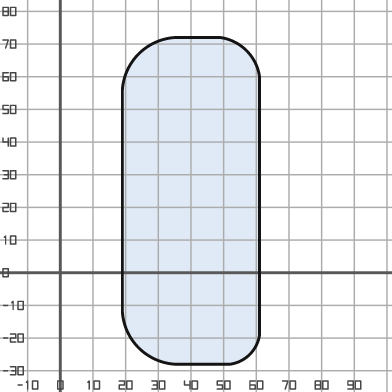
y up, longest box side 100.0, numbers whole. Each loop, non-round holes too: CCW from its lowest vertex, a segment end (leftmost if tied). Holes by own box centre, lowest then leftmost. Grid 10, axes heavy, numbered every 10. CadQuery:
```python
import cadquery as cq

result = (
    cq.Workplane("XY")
    .moveTo(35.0, -28.0)
    .lineTo(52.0, -28.0)
    .threePointArc((58.0, -25.0), (61.0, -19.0))
    .lineTo(61.0, 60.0)
    .threePointArc((57.0, 68.0), (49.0, 72.0))
    .lineTo(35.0, 72.0)
    .threePointArc((24.0, 67.0), (19.0, 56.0))
    .lineTo(19.0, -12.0)
    .threePointArc((24.0, -23.0), (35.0, -28.0))
    .close()
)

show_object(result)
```